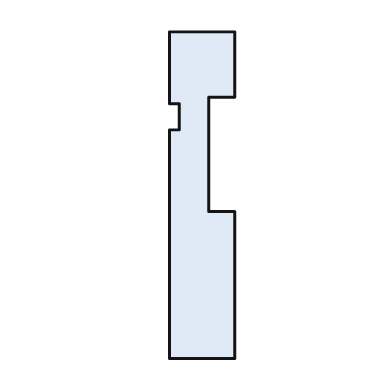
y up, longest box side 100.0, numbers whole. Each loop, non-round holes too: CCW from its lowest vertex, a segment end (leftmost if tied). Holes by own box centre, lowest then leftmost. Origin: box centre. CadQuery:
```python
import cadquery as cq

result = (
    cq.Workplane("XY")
    .moveTo(-10.0, -50.0)
    .lineTo(10.0, -50.0)
    .lineTo(10.0, -5.0)
    .lineTo(2.0, -5.0)
    .lineTo(2.0, 30.0)
    .lineTo(10.0, 30.0)
    .lineTo(10.0, 50.0)
    .lineTo(-10.0, 50.0)
    .lineTo(-10.0, 28.0)
    .lineTo(-7.0, 28.0)
    .lineTo(-7.0, 20.0)
    .lineTo(-10.0, 20.0)
    .close()
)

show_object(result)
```